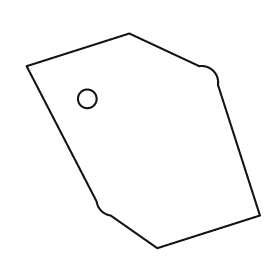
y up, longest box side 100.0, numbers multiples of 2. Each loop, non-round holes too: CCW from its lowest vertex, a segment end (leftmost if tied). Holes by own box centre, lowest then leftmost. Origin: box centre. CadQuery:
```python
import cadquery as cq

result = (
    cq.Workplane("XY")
    .moveTo(6.0, -46.0)
    .lineTo(50.0, -32.0)
    .lineTo(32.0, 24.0)
    .threePointArc((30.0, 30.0), (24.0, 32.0))
    .lineTo(-6.0, 46.0)
    .lineTo(-50.0, 32.0)
    .lineTo(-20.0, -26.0)
    .threePointArc((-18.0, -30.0), (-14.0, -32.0))
    .close()
    .moveTo(-24.0, 18.0)
    .circle(4.0)
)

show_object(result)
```